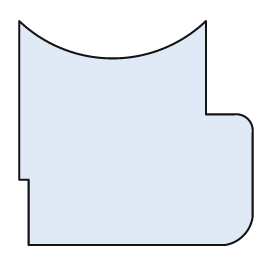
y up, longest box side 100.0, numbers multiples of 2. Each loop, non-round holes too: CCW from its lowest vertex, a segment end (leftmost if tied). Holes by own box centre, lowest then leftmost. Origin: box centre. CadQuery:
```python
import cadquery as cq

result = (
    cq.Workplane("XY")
    .moveTo(-46.0, -48.0)
    .lineTo(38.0, -48.0)
    .threePointArc((46.0, -44.0), (50.0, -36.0))
    .lineTo(50.0, 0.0)
    .threePointArc((48.0, 6.0), (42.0, 8.0))
    .lineTo(30.0, 8.0)
    .lineTo(30.0, 48.0)
    .threePointArc((-10.0, 32.0), (-50.0, 48.0))
    .lineTo(-50.0, -20.0)
    .lineTo(-46.0, -20.0)
    .close()
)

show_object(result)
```